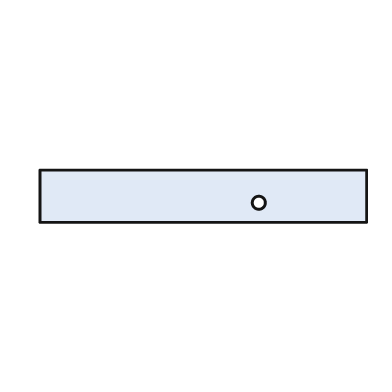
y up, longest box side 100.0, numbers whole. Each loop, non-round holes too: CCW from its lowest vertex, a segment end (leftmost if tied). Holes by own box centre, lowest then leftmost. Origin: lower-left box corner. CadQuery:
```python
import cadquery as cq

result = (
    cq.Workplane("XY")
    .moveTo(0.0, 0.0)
    .lineTo(100.0, 0.0)
    .lineTo(100.0, 16.0)
    .lineTo(0.0, 16.0)
    .close()
    .moveTo(67.0, 6.0)
    .circle(2.0)
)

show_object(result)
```